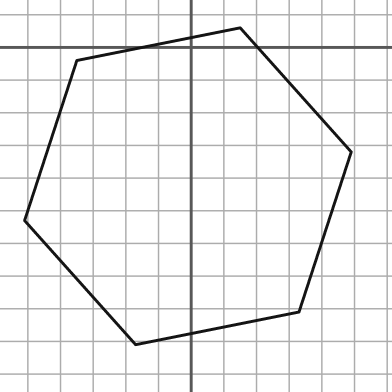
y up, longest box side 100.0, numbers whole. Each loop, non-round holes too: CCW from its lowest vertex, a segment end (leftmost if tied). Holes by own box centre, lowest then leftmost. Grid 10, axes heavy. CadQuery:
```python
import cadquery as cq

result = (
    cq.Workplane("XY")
    .moveTo(-17.0, -91.0)
    .lineTo(33.0, -81.0)
    .lineTo(49.0, -32.0)
    .lineTo(15.0, 6.0)
    .lineTo(-35.0, -4.0)
    .lineTo(-51.0, -53.0)
    .close()
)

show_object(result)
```